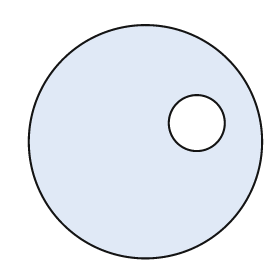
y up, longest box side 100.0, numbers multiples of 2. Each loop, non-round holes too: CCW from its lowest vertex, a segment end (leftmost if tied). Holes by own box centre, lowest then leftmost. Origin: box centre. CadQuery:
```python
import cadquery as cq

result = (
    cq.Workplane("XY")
    .moveTo(0.0, 0.0)
    .circle(50.0)
    .moveTo(22.0, 8.0)
    .circle(12.0)
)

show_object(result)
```